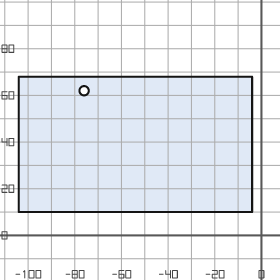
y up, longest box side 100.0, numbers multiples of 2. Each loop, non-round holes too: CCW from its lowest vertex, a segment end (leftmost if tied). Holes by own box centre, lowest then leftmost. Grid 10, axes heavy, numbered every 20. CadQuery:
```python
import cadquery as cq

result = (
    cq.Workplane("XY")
    .moveTo(-104.0, 10.0)
    .lineTo(-4.0, 10.0)
    .lineTo(-4.0, 68.0)
    .lineTo(-104.0, 68.0)
    .close()
    .moveTo(-76.0, 62.0)
    .circle(2.0)
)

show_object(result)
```